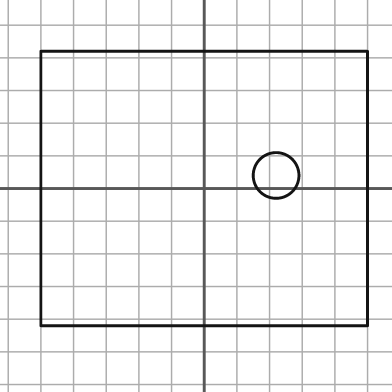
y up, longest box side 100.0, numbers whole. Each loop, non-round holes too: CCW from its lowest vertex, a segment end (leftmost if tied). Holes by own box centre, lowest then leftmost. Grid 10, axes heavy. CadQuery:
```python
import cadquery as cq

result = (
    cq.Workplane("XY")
    .moveTo(-50.0, -42.0)
    .lineTo(50.0, -42.0)
    .lineTo(50.0, 42.0)
    .lineTo(-50.0, 42.0)
    .close()
    .moveTo(22.0, 4.0)
    .circle(7.0)
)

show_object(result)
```